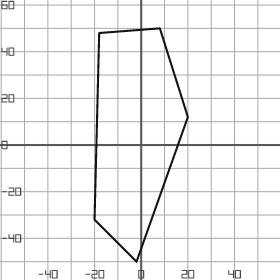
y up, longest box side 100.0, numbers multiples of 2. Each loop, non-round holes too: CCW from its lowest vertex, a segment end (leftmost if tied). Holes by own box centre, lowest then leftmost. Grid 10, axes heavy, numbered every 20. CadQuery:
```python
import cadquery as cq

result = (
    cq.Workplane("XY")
    .moveTo(-2.0, -50.0)
    .lineTo(20.0, 12.0)
    .lineTo(8.0, 50.0)
    .lineTo(-18.0, 48.0)
    .lineTo(-20.0, -32.0)
    .close()
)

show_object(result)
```